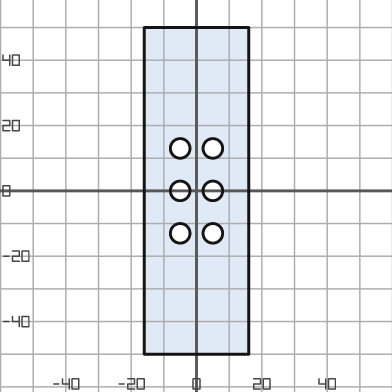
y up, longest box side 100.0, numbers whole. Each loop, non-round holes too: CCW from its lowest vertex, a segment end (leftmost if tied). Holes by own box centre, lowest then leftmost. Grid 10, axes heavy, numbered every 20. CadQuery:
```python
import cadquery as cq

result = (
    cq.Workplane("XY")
    .moveTo(-16.0, -50.0)
    .lineTo(16.0, -50.0)
    .lineTo(16.0, 50.0)
    .lineTo(-16.0, 50.0)
    .close()
    .moveTo(-5.0, -13.0)
    .circle(3.0)
    .moveTo(5.0, -13.0)
    .circle(3.0)
    .moveTo(-5.0, 0.0)
    .circle(3.0)
    .moveTo(5.0, 0.0)
    .circle(3.0)
    .moveTo(-5.0, 13.0)
    .circle(3.0)
    .moveTo(5.0, 13.0)
    .circle(3.0)
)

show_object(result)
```